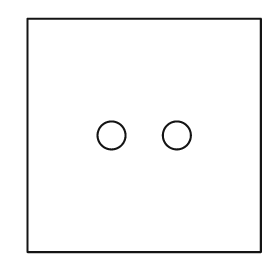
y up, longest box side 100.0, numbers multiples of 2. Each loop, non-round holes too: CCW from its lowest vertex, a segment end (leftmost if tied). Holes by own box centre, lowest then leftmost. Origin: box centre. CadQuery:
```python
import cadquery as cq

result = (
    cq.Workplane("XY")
    .moveTo(-50.0, -50.0)
    .lineTo(50.0, -50.0)
    .lineTo(50.0, 50.0)
    .lineTo(-50.0, 50.0)
    .close()
    .moveTo(-14.0, 0.0)
    .circle(6.0)
    .moveTo(14.0, 0.0)
    .circle(6.0)
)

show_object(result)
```